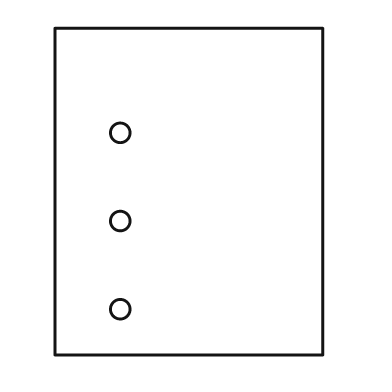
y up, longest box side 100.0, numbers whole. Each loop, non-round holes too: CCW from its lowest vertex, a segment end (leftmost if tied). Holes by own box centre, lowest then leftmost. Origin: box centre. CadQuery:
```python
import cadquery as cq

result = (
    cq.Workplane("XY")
    .moveTo(-41.0, -50.0)
    .lineTo(41.0, -50.0)
    .lineTo(41.0, 50.0)
    .lineTo(-41.0, 50.0)
    .close()
    .moveTo(-21.0, -36.0)
    .circle(3.0)
    .moveTo(-21.0, -9.0)
    .circle(3.0)
    .moveTo(-21.0, 18.0)
    .circle(3.0)
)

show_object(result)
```